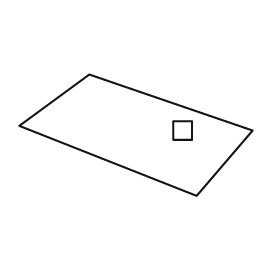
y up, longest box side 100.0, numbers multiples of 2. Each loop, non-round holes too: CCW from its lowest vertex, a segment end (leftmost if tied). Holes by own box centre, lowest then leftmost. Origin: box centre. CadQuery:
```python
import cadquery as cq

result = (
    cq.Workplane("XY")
    .moveTo(26.0, -26.0)
    .lineTo(50.0, 2.0)
    .lineTo(-20.0, 26.0)
    .lineTo(-50.0, 4.0)
    .close()
    .moveTo(16.0, -2.0)
    .lineTo(24.0, -2.0)
    .lineTo(24.0, 6.0)
    .lineTo(16.0, 6.0)
    .close()
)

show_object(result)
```